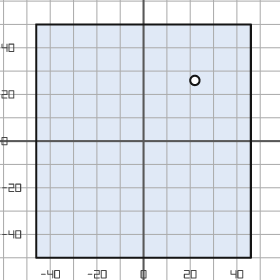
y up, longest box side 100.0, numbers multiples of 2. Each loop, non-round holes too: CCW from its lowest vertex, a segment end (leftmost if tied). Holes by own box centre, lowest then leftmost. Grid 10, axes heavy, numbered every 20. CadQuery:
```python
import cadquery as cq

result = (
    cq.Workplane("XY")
    .moveTo(-46.0, -50.0)
    .lineTo(46.0, -50.0)
    .lineTo(46.0, 50.0)
    .lineTo(-46.0, 50.0)
    .close()
    .moveTo(22.0, 26.0)
    .circle(2.0)
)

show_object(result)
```